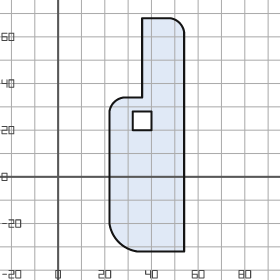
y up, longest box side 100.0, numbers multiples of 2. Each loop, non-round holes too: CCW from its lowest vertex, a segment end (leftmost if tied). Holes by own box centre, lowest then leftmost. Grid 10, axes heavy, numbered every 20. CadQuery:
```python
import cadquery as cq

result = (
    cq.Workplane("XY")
    .moveTo(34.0, -32.0)
    .lineTo(54.0, -32.0)
    .lineTo(54.0, 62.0)
    .threePointArc((52.0, 66.0), (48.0, 68.0))
    .lineTo(36.0, 68.0)
    .lineTo(36.0, 34.0)
    .lineTo(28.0, 34.0)
    .threePointArc((24.0, 32.0), (22.0, 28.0))
    .lineTo(22.0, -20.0)
    .threePointArc((26.0, -28.0), (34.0, -32.0))
    .close()
    .moveTo(32.0, 20.0)
    .lineTo(40.0, 20.0)
    .lineTo(40.0, 28.0)
    .lineTo(32.0, 28.0)
    .close()
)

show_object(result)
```